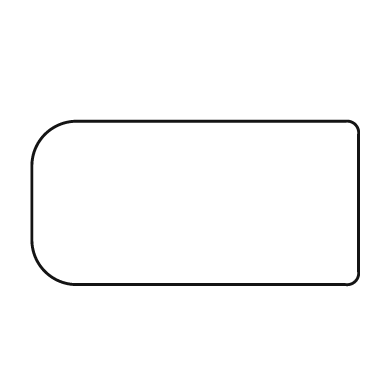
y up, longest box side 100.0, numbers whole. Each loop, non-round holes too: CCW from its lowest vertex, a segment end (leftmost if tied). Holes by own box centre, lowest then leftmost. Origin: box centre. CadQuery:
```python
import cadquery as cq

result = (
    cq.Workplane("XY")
    .moveTo(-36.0, -25.0)
    .lineTo(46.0, -25.0)
    .threePointArc((49.0, -24.0), (50.0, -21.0))
    .lineTo(50.0, 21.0)
    .threePointArc((49.0, 24.0), (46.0, 25.0))
    .lineTo(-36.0, 25.0)
    .threePointArc((-46.0, 21.0), (-50.0, 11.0))
    .lineTo(-50.0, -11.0)
    .threePointArc((-46.0, -21.0), (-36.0, -25.0))
    .close()
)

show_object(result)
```